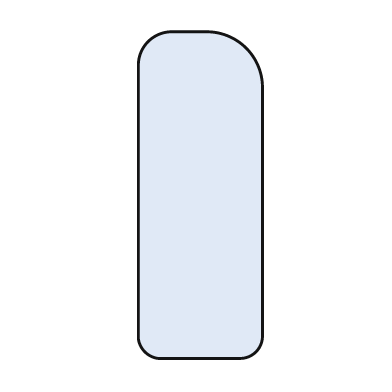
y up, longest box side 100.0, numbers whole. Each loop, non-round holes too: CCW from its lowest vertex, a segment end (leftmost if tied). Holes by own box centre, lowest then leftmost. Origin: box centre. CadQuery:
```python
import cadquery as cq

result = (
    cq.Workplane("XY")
    .moveTo(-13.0, -50.0)
    .lineTo(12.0, -50.0)
    .threePointArc((17.0, -48.0), (19.0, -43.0))
    .lineTo(19.0, 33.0)
    .threePointArc((14.0, 45.0), (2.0, 50.0))
    .lineTo(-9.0, 50.0)
    .threePointArc((-16.0, 47.0), (-19.0, 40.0))
    .lineTo(-19.0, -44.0)
    .threePointArc((-17.0, -48.0), (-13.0, -50.0))
    .close()
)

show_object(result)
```